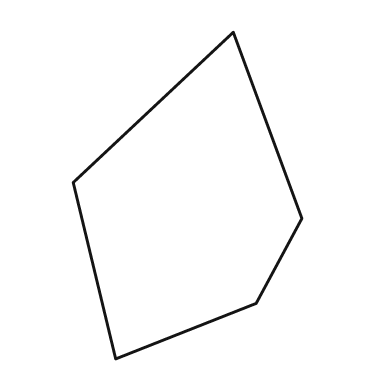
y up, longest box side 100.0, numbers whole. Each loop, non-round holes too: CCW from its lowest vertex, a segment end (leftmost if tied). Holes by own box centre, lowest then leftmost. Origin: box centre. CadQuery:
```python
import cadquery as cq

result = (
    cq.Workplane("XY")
    .moveTo(-22.0, -50.0)
    .lineTo(21.0, -33.0)
    .lineTo(35.0, -7.0)
    .lineTo(14.0, 50.0)
    .lineTo(-35.0, 4.0)
    .close()
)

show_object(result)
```